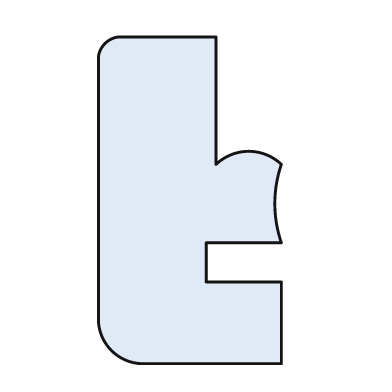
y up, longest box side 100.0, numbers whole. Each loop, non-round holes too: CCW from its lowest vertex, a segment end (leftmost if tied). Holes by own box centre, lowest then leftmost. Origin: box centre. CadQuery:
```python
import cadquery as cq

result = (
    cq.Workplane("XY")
    .moveTo(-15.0, -50.0)
    .lineTo(28.0, -50.0)
    .lineTo(28.0, -25.0)
    .lineTo(5.0, -25.0)
    .lineTo(5.0, -13.0)
    .lineTo(28.0, -13.0)
    .threePointArc((26.0, -1.0), (28.0, 11.0))
    .threePointArc((18.0, 15.0), (8.0, 11.0))
    .lineTo(8.0, 50.0)
    .lineTo(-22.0, 50.0)
    .threePointArc((-26.0, 48.0), (-28.0, 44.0))
    .lineTo(-28.0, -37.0)
    .threePointArc((-24.0, -46.0), (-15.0, -50.0))
    .close()
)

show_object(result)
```